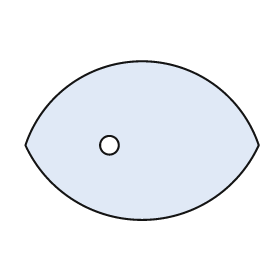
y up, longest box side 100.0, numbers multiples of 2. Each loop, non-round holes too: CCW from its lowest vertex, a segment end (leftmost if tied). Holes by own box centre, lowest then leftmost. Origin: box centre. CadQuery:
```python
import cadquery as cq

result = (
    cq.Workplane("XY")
    .moveTo(-50.0, -2.0)
    .threePointArc((0.0, -34.0), (50.0, -2.0))
    .threePointArc((0.0, 34.0), (-50.0, -2.0))
    .close()
    .moveTo(-14.0, -2.0)
    .circle(4.0)
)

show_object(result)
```